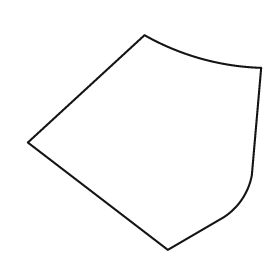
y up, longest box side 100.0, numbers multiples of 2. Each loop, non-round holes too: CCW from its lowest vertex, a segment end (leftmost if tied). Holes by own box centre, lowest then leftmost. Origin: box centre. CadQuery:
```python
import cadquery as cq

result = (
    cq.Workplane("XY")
    .moveTo(10.0, -46.0)
    .lineTo(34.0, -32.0)
    .threePointArc((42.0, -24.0), (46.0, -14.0))
    .lineTo(50.0, 32.0)
    .threePointArc((24.0, 36.0), (0.0, 46.0))
    .lineTo(-50.0, 0.0)
    .close()
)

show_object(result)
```